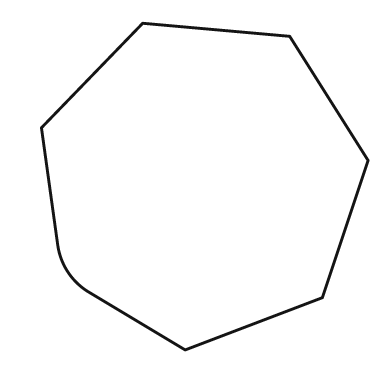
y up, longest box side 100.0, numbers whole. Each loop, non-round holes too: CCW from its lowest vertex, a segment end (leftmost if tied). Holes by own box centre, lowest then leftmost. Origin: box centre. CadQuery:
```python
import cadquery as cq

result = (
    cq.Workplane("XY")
    .moveTo(-6.0, -50.0)
    .lineTo(36.0, -34.0)
    .lineTo(50.0, 8.0)
    .lineTo(26.0, 46.0)
    .lineTo(-19.0, 50.0)
    .lineTo(-50.0, 18.0)
    .lineTo(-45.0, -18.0)
    .threePointArc((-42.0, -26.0), (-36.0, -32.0))
    .close()
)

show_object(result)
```